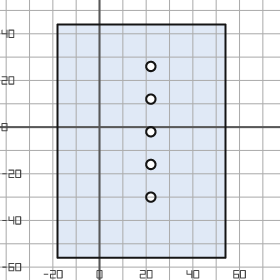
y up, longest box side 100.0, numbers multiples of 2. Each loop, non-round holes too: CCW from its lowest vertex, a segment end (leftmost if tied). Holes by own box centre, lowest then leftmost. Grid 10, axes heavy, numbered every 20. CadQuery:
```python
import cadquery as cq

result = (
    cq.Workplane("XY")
    .moveTo(-18.0, -56.0)
    .lineTo(54.0, -56.0)
    .lineTo(54.0, 44.0)
    .lineTo(-18.0, 44.0)
    .close()
    .moveTo(22.0, -30.0)
    .circle(2.0)
    .moveTo(22.0, -16.0)
    .circle(2.0)
    .moveTo(22.0, -2.0)
    .circle(2.0)
    .moveTo(22.0, 12.0)
    .circle(2.0)
    .moveTo(22.0, 26.0)
    .circle(2.0)
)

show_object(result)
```